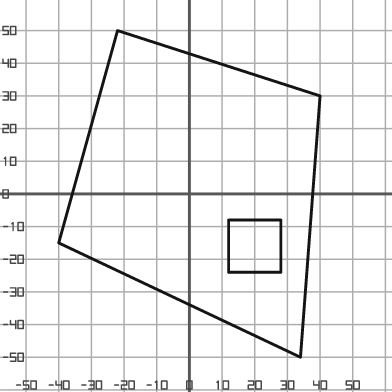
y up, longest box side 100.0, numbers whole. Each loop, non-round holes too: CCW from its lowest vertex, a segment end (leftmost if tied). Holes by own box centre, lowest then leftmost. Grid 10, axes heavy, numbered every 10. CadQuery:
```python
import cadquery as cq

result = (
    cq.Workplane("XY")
    .moveTo(34.0, -50.0)
    .lineTo(40.0, 30.0)
    .lineTo(-22.0, 50.0)
    .lineTo(-40.0, -15.0)
    .close()
    .moveTo(12.0, -24.0)
    .lineTo(28.0, -24.0)
    .lineTo(28.0, -8.0)
    .lineTo(12.0, -8.0)
    .close()
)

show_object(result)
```